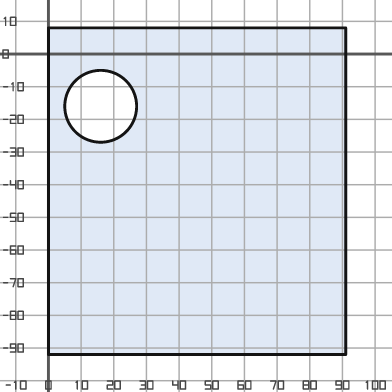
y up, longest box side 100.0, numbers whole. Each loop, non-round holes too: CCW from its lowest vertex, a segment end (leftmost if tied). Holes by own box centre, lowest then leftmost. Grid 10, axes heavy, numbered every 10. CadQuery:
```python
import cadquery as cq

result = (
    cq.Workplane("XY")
    .moveTo(0.0, -92.0)
    .lineTo(91.0, -92.0)
    .lineTo(91.0, 8.0)
    .lineTo(0.0, 8.0)
    .close()
    .moveTo(16.0, -16.0)
    .circle(11.0)
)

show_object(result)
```